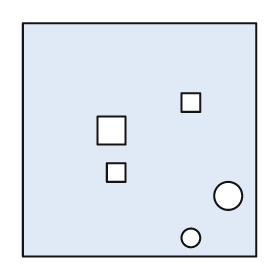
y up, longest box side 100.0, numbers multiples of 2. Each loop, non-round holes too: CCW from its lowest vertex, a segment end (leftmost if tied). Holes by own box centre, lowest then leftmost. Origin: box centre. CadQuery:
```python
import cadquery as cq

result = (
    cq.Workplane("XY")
    .moveTo(-50.0, -50.0)
    .lineTo(50.0, -50.0)
    .lineTo(50.0, 50.0)
    .lineTo(-50.0, 50.0)
    .close()
    .moveTo(22.0, -42.0)
    .circle(4.0)
    .moveTo(38.0, -24.0)
    .circle(6.0)
    .moveTo(-14.0, -18.0)
    .lineTo(-6.0, -18.0)
    .lineTo(-6.0, -10.0)
    .lineTo(-14.0, -10.0)
    .close()
    .moveTo(-18.0, -2.0)
    .lineTo(-6.0, -2.0)
    .lineTo(-6.0, 10.0)
    .lineTo(-18.0, 10.0)
    .close()
    .moveTo(18.0, 12.0)
    .lineTo(26.0, 12.0)
    .lineTo(26.0, 20.0)
    .lineTo(18.0, 20.0)
    .close()
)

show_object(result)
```